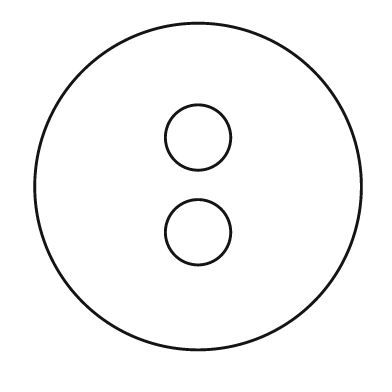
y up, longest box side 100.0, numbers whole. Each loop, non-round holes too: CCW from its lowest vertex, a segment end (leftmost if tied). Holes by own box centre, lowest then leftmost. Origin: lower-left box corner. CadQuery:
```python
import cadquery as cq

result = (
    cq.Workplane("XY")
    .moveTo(50.0, 50.0)
    .circle(50.0)
    .moveTo(50.0, 36.0)
    .circle(10.0)
    .moveTo(50.0, 65.0)
    .circle(10.0)
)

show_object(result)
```